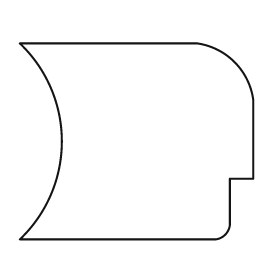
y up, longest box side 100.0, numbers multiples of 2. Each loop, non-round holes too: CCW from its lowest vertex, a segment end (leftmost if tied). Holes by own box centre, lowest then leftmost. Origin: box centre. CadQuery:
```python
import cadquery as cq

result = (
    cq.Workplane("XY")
    .moveTo(-50.0, -42.0)
    .lineTo(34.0, -42.0)
    .threePointArc((38.0, -40.0), (40.0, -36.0))
    .lineTo(40.0, -16.0)
    .lineTo(50.0, -16.0)
    .lineTo(50.0, 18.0)
    .threePointArc((42.0, 34.0), (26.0, 42.0))
    .lineTo(-50.0, 42.0)
    .threePointArc((-32.0, 0.0), (-50.0, -42.0))
    .close()
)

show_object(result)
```